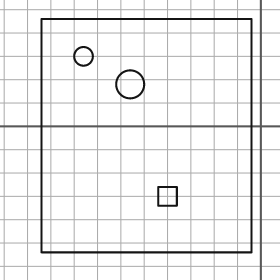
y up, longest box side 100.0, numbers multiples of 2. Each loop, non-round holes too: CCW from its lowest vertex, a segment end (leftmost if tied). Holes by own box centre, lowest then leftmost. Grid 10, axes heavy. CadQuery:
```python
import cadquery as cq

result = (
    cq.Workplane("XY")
    .moveTo(-94.0, -54.0)
    .lineTo(-4.0, -54.0)
    .lineTo(-4.0, 46.0)
    .lineTo(-94.0, 46.0)
    .close()
    .moveTo(-44.0, -34.0)
    .lineTo(-36.0, -34.0)
    .lineTo(-36.0, -26.0)
    .lineTo(-44.0, -26.0)
    .close()
    .moveTo(-56.0, 18.0)
    .circle(6.0)
    .moveTo(-76.0, 30.0)
    .circle(4.0)
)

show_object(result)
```